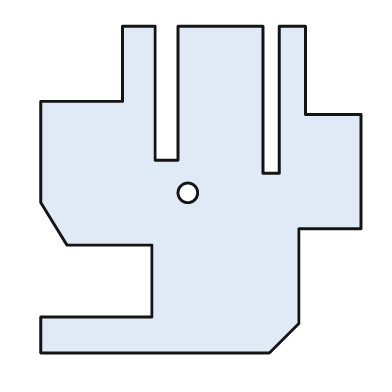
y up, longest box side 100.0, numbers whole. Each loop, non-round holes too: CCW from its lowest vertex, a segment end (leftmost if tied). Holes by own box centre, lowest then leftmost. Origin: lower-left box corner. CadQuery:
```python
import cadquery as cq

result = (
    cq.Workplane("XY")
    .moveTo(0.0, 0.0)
    .lineTo(70.0, 0.0)
    .lineTo(79.0, 9.0)
    .lineTo(79.0, 38.0)
    .lineTo(98.0, 38.0)
    .lineTo(98.0, 73.0)
    .lineTo(81.0, 73.0)
    .lineTo(81.0, 100.0)
    .lineTo(73.0, 100.0)
    .lineTo(73.0, 55.0)
    .lineTo(68.0, 55.0)
    .lineTo(68.0, 100.0)
    .lineTo(42.0, 100.0)
    .lineTo(42.0, 59.0)
    .lineTo(35.0, 59.0)
    .lineTo(35.0, 100.0)
    .lineTo(25.0, 100.0)
    .lineTo(25.0, 77.0)
    .lineTo(0.0, 77.0)
    .lineTo(0.0, 46.0)
    .lineTo(8.0, 33.0)
    .lineTo(34.0, 33.0)
    .lineTo(34.0, 11.0)
    .lineTo(0.0, 11.0)
    .close()
    .moveTo(45.0, 49.0)
    .circle(3.0)
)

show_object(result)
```